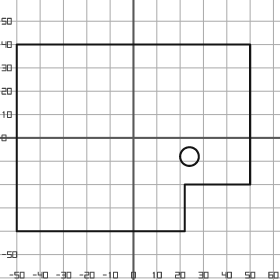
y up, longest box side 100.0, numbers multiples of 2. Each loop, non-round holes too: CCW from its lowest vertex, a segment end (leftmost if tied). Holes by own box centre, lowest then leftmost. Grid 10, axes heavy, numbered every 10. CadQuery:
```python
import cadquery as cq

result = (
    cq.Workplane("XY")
    .moveTo(-50.0, -40.0)
    .lineTo(22.0, -40.0)
    .lineTo(22.0, -20.0)
    .lineTo(50.0, -20.0)
    .lineTo(50.0, 40.0)
    .lineTo(-50.0, 40.0)
    .close()
    .moveTo(24.0, -8.0)
    .circle(4.0)
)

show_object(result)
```